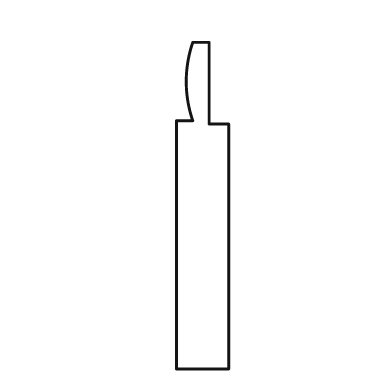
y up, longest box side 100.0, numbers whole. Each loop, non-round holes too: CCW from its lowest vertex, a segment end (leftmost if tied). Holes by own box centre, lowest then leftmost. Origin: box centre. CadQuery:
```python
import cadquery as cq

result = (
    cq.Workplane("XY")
    .moveTo(-8.0, -50.0)
    .lineTo(8.0, -50.0)
    .lineTo(8.0, 25.0)
    .lineTo(2.0, 25.0)
    .lineTo(2.0, 50.0)
    .lineTo(-3.0, 50.0)
    .threePointArc((-5.0, 38.0), (-3.0, 26.0))
    .lineTo(-8.0, 26.0)
    .close()
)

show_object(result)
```